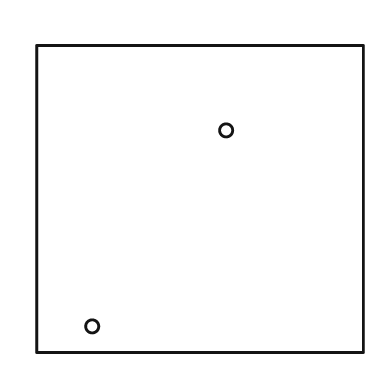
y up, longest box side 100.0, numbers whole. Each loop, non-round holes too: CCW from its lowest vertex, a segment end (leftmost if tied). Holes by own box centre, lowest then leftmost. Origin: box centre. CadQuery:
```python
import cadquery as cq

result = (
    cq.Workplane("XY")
    .moveTo(-50.0, -47.0)
    .lineTo(50.0, -47.0)
    .lineTo(50.0, 47.0)
    .lineTo(-50.0, 47.0)
    .close()
    .moveTo(-33.0, -39.0)
    .circle(2.0)
    .moveTo(8.0, 21.0)
    .circle(2.0)
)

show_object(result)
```